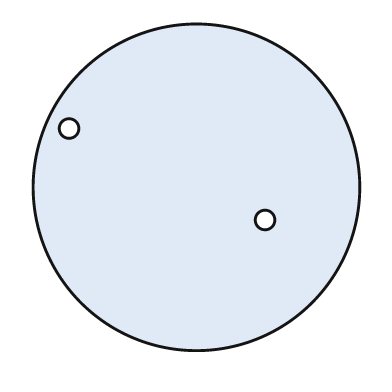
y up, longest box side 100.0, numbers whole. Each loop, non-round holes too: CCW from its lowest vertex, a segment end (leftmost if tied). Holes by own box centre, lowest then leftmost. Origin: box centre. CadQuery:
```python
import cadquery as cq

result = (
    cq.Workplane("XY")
    .moveTo(0.0, 0.0)
    .circle(50.0)
    .moveTo(21.0, -10.0)
    .circle(3.0)
    .moveTo(-39.0, 18.0)
    .circle(3.0)
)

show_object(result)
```